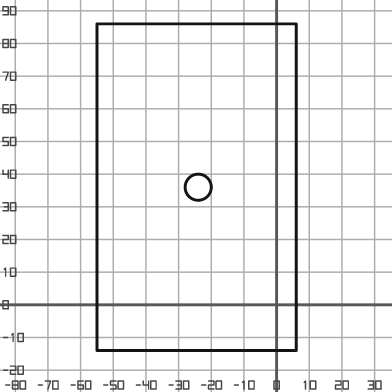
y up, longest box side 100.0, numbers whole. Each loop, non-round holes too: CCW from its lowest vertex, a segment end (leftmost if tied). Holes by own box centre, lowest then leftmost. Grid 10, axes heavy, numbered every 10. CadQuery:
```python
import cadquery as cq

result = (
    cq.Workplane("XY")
    .moveTo(-55.0, -14.0)
    .lineTo(6.0, -14.0)
    .lineTo(6.0, 86.0)
    .lineTo(-55.0, 86.0)
    .close()
    .moveTo(-24.0, 36.0)
    .circle(4.0)
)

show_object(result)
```